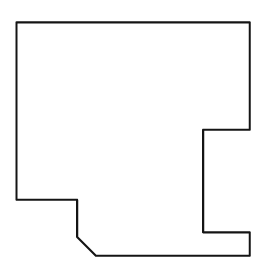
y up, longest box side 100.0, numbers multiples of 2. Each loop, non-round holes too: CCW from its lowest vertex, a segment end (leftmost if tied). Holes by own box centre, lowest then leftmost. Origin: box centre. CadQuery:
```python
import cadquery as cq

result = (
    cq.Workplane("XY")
    .moveTo(-16.0, -50.0)
    .lineTo(50.0, -50.0)
    .lineTo(50.0, -40.0)
    .lineTo(30.0, -40.0)
    .lineTo(30.0, 4.0)
    .lineTo(50.0, 4.0)
    .lineTo(50.0, 50.0)
    .lineTo(-50.0, 50.0)
    .lineTo(-50.0, -26.0)
    .lineTo(-24.0, -26.0)
    .lineTo(-24.0, -42.0)
    .close()
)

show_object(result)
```